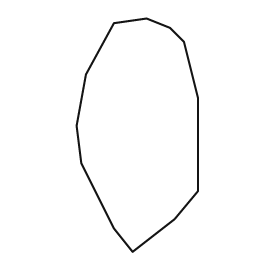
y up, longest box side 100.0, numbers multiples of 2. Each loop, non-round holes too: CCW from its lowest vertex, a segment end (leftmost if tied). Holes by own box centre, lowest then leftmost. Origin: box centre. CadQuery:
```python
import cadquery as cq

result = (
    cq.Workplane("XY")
    .moveTo(-2.0, -50.0)
    .lineTo(16.0, -36.0)
    .lineTo(26.0, -24.0)
    .lineTo(26.0, 16.0)
    .lineTo(20.0, 40.0)
    .lineTo(14.0, 46.0)
    .lineTo(4.0, 50.0)
    .lineTo(-10.0, 48.0)
    .lineTo(-22.0, 26.0)
    .lineTo(-26.0, 4.0)
    .lineTo(-24.0, -12.0)
    .lineTo(-10.0, -40.0)
    .close()
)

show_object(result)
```